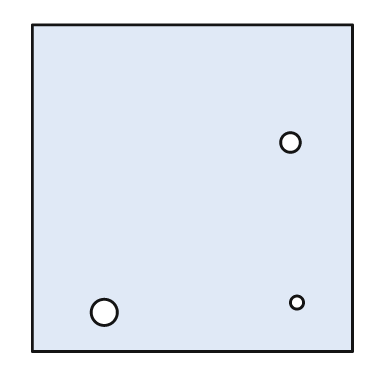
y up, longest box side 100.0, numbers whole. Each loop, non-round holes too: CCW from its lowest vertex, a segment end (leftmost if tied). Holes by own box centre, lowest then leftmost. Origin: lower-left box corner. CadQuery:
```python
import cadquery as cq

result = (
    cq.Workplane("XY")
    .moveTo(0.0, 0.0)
    .lineTo(98.0, 0.0)
    .lineTo(98.0, 100.0)
    .lineTo(0.0, 100.0)
    .close()
    .moveTo(22.0, 12.0)
    .circle(4.0)
    .moveTo(81.0, 15.0)
    .circle(2.0)
    .moveTo(79.0, 64.0)
    .circle(3.0)
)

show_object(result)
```